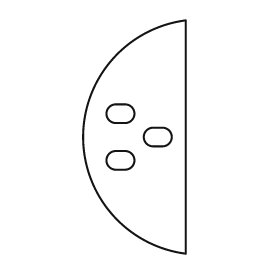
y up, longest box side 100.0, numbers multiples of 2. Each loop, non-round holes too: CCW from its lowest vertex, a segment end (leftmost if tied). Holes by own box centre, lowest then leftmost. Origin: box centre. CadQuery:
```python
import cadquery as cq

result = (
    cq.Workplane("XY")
    .moveTo(22.0, -50.0)
    .lineTo(22.0, 50.0)
    .threePointArc((-22.0, 0.0), (22.0, -50.0))
    .close()
    .moveTo(-8.0, -14.0)
    .lineTo(-4.0, -14.0)
    .threePointArc((0.0, -10.0), (-4.0, -6.0))
    .lineTo(-8.0, -6.0)
    .threePointArc((-12.0, -10.0), (-8.0, -14.0))
    .close()
    .moveTo(8.0, -4.0)
    .lineTo(12.0, -4.0)
    .threePointArc((16.0, 0.0), (12.0, 4.0))
    .lineTo(8.0, 4.0)
    .threePointArc((4.0, 0.0), (8.0, -4.0))
    .close()
    .moveTo(-8.0, 6.0)
    .lineTo(-4.0, 6.0)
    .threePointArc((0.0, 10.0), (-4.0, 14.0))
    .lineTo(-8.0, 14.0)
    .threePointArc((-12.0, 10.0), (-8.0, 6.0))
    .close()
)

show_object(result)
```